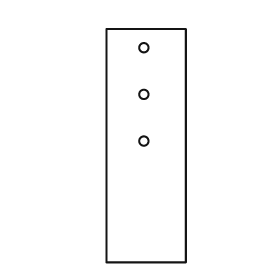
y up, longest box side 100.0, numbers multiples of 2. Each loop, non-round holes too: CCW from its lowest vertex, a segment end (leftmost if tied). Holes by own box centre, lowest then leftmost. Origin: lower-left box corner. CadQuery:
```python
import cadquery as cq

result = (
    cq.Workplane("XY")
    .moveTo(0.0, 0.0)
    .lineTo(34.0, 0.0)
    .lineTo(34.0, 100.0)
    .lineTo(0.0, 100.0)
    .close()
    .moveTo(16.0, 52.0)
    .circle(2.0)
    .moveTo(16.0, 72.0)
    .circle(2.0)
    .moveTo(16.0, 92.0)
    .circle(2.0)
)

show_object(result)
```